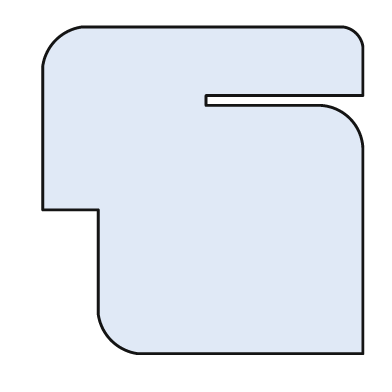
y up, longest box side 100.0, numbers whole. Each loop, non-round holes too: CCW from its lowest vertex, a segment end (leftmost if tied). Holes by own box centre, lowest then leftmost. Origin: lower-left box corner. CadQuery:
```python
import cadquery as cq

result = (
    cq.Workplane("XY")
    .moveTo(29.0, 0.0)
    .lineTo(98.0, 0.0)
    .lineTo(98.0, 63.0)
    .threePointArc((94.0, 72.0), (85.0, 76.0))
    .lineTo(50.0, 76.0)
    .lineTo(50.0, 79.0)
    .lineTo(98.0, 79.0)
    .lineTo(98.0, 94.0)
    .threePointArc((96.0, 98.0), (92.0, 100.0))
    .lineTo(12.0, 100.0)
    .threePointArc((4.0, 96.0), (0.0, 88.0))
    .lineTo(0.0, 44.0)
    .lineTo(17.0, 44.0)
    .lineTo(17.0, 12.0)
    .threePointArc((21.0, 4.0), (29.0, 0.0))
    .close()
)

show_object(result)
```